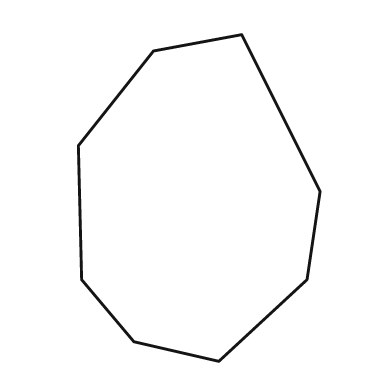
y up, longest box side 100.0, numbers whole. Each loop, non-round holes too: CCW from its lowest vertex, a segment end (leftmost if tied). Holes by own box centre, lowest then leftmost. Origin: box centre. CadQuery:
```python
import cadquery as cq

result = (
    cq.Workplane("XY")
    .moveTo(6.0, -50.0)
    .lineTo(33.0, -25.0)
    .lineTo(37.0, 2.0)
    .lineTo(13.0, 50.0)
    .lineTo(-14.0, 45.0)
    .lineTo(-37.0, 16.0)
    .lineTo(-36.0, -25.0)
    .lineTo(-20.0, -44.0)
    .close()
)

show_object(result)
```